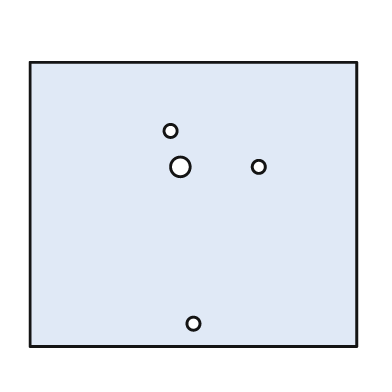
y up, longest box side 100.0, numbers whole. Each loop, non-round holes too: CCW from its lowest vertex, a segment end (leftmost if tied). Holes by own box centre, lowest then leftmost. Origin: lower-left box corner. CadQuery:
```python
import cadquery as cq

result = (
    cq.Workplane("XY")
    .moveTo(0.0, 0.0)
    .lineTo(100.0, 0.0)
    .lineTo(100.0, 87.0)
    .lineTo(0.0, 87.0)
    .close()
    .moveTo(50.0, 7.0)
    .circle(2.0)
    .moveTo(46.0, 55.0)
    .circle(3.0)
    .moveTo(70.0, 55.0)
    .circle(2.0)
    .moveTo(43.0, 66.0)
    .circle(2.0)
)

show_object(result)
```